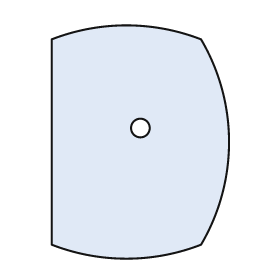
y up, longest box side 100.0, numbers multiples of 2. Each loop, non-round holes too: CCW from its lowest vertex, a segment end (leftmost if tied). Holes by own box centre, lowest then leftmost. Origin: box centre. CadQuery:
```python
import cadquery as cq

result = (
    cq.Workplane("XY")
    .moveTo(-38.0, -44.0)
    .threePointArc((-6.0, -50.0), (26.0, -44.0))
    .threePointArc((38.0, 0.0), (26.0, 44.0))
    .threePointArc((-6.0, 50.0), (-38.0, 44.0))
    .close()
    .moveTo(0.0, 6.0)
    .circle(4.0)
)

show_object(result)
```